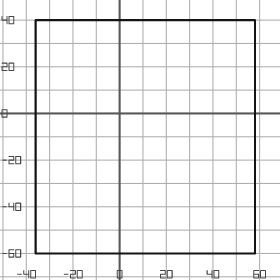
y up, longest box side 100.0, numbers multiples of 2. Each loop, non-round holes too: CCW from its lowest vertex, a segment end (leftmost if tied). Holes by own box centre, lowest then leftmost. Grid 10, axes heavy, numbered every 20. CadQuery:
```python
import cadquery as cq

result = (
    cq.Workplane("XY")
    .moveTo(-36.0, -60.0)
    .lineTo(58.0, -60.0)
    .lineTo(58.0, 40.0)
    .lineTo(-36.0, 40.0)
    .close()
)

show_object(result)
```